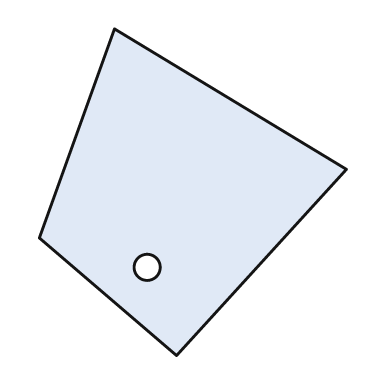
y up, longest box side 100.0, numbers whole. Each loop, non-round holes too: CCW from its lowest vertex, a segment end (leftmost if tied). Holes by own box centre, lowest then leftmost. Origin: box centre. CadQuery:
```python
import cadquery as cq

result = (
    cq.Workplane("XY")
    .moveTo(-5.0, -50.0)
    .lineTo(47.0, 7.0)
    .lineTo(-24.0, 50.0)
    .lineTo(-47.0, -14.0)
    .close()
    .moveTo(-14.0, -23.0)
    .circle(4.0)
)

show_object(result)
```